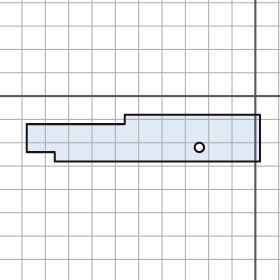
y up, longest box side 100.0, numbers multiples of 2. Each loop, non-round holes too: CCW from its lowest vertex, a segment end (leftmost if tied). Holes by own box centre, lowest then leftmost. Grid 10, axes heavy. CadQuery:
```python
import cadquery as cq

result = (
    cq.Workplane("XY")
    .moveTo(-86.0, -28.0)
    .lineTo(2.0, -28.0)
    .lineTo(2.0, -8.0)
    .lineTo(-56.0, -8.0)
    .lineTo(-56.0, -12.0)
    .lineTo(-98.0, -12.0)
    .lineTo(-98.0, -24.0)
    .lineTo(-86.0, -24.0)
    .close()
    .moveTo(-24.0, -22.0)
    .circle(2.0)
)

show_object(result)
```